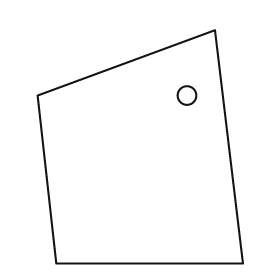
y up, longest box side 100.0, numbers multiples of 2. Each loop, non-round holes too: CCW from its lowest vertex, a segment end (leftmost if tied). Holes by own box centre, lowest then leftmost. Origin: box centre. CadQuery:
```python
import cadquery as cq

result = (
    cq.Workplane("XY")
    .moveTo(-36.0, -50.0)
    .lineTo(44.0, -50.0)
    .lineTo(32.0, 50.0)
    .lineTo(-44.0, 22.0)
    .close()
    .moveTo(20.0, 22.0)
    .circle(4.0)
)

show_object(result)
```